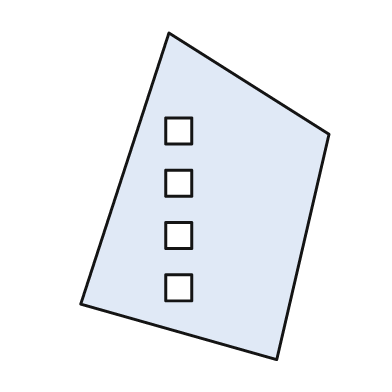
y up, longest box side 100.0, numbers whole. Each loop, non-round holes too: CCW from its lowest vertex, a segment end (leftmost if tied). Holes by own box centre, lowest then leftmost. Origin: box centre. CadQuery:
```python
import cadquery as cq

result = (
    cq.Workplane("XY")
    .moveTo(22.0, -50.0)
    .lineTo(38.0, 19.0)
    .lineTo(-11.0, 50.0)
    .lineTo(-38.0, -33.0)
    .close()
    .moveTo(-12.0, -32.0)
    .lineTo(-4.0, -32.0)
    .lineTo(-4.0, -24.0)
    .lineTo(-12.0, -24.0)
    .close()
    .moveTo(-12.0, -16.0)
    .lineTo(-4.0, -16.0)
    .lineTo(-4.0, -8.0)
    .lineTo(-12.0, -8.0)
    .close()
    .moveTo(-12.0, 0.0)
    .lineTo(-4.0, 0.0)
    .lineTo(-4.0, 8.0)
    .lineTo(-12.0, 8.0)
    .close()
    .moveTo(-12.0, 16.0)
    .lineTo(-4.0, 16.0)
    .lineTo(-4.0, 24.0)
    .lineTo(-12.0, 24.0)
    .close()
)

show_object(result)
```